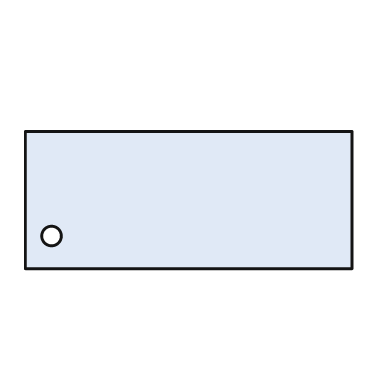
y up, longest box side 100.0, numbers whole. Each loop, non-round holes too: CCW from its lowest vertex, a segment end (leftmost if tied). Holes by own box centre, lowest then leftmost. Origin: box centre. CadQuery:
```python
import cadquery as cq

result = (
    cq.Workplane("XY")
    .moveTo(-50.0, -21.0)
    .lineTo(50.0, -21.0)
    .lineTo(50.0, 21.0)
    .lineTo(-50.0, 21.0)
    .close()
    .moveTo(-42.0, -11.0)
    .circle(3.0)
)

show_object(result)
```